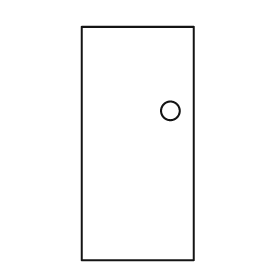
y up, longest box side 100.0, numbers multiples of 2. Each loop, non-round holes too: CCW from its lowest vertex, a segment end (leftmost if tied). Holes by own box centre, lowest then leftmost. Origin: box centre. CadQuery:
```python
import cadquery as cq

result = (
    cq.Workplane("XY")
    .moveTo(-24.0, -50.0)
    .lineTo(24.0, -50.0)
    .lineTo(24.0, 50.0)
    .lineTo(-24.0, 50.0)
    .close()
    .moveTo(14.0, 14.0)
    .circle(4.0)
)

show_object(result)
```